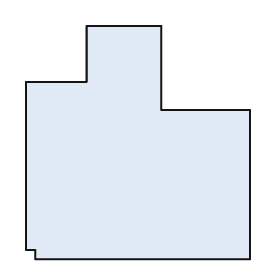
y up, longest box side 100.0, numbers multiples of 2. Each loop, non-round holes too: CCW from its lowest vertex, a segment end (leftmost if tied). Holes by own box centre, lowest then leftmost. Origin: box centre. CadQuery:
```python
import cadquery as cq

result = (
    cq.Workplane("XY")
    .moveTo(-44.0, -50.0)
    .lineTo(48.0, -50.0)
    .lineTo(48.0, 14.0)
    .lineTo(10.0, 14.0)
    .lineTo(10.0, 50.0)
    .lineTo(-22.0, 50.0)
    .lineTo(-22.0, 26.0)
    .lineTo(-48.0, 26.0)
    .lineTo(-48.0, -46.0)
    .lineTo(-44.0, -46.0)
    .close()
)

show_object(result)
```